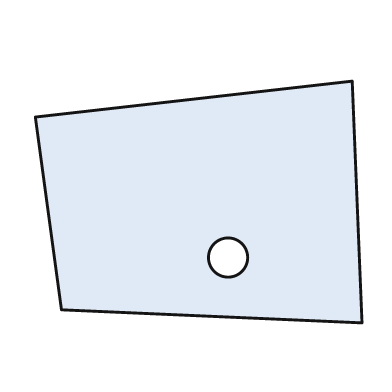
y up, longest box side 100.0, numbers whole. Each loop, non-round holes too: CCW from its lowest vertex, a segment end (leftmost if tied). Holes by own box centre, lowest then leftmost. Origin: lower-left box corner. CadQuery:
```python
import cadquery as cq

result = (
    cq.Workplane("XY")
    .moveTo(100.0, 0.0)
    .lineTo(97.0, 74.0)
    .lineTo(0.0, 63.0)
    .lineTo(8.0, 4.0)
    .close()
    .moveTo(59.0, 20.0)
    .circle(6.0)
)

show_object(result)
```